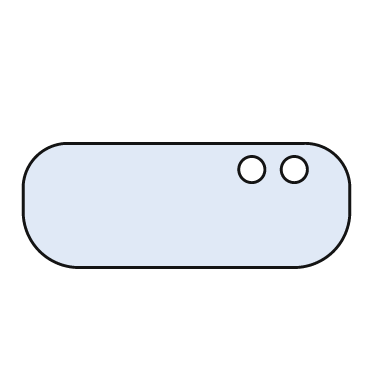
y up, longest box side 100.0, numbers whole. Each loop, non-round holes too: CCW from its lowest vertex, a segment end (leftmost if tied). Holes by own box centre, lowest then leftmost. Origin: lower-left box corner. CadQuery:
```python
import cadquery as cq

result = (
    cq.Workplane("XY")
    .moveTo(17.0, 0.0)
    .lineTo(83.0, 0.0)
    .threePointArc((95.0, 5.0), (100.0, 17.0))
    .lineTo(100.0, 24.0)
    .threePointArc((96.0, 34.0), (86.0, 38.0))
    .lineTo(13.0, 38.0)
    .threePointArc((4.0, 34.0), (0.0, 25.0))
    .lineTo(0.0, 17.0)
    .threePointArc((5.0, 5.0), (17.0, 0.0))
    .close()
    .moveTo(70.0, 30.0)
    .circle(4.0)
    .moveTo(83.0, 30.0)
    .circle(4.0)
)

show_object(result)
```